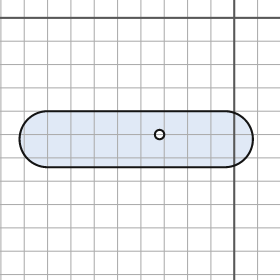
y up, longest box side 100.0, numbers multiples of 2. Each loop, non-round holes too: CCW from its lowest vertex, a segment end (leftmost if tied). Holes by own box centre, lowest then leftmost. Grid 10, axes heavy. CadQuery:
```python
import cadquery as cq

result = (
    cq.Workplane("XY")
    .moveTo(-80.0, -64.0)
    .lineTo(-4.0, -64.0)
    .threePointArc((8.0, -52.0), (-4.0, -40.0))
    .lineTo(-80.0, -40.0)
    .threePointArc((-92.0, -52.0), (-80.0, -64.0))
    .close()
    .moveTo(-32.0, -50.0)
    .circle(2.0)
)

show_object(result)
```